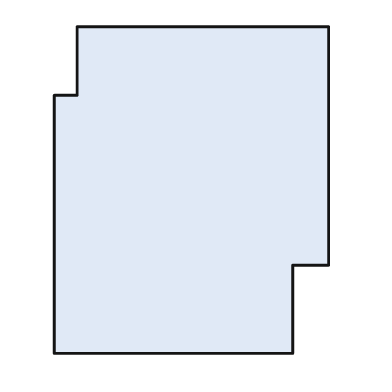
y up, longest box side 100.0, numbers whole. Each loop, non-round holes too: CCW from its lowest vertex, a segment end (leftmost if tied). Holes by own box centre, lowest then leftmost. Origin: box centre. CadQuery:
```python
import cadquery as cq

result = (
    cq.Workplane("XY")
    .moveTo(-42.0, -50.0)
    .lineTo(31.0, -50.0)
    .lineTo(31.0, -23.0)
    .lineTo(42.0, -23.0)
    .lineTo(42.0, 50.0)
    .lineTo(-35.0, 50.0)
    .lineTo(-35.0, 29.0)
    .lineTo(-42.0, 29.0)
    .close()
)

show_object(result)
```